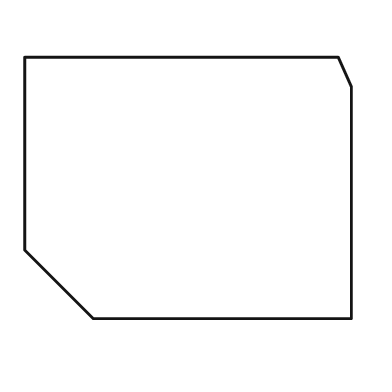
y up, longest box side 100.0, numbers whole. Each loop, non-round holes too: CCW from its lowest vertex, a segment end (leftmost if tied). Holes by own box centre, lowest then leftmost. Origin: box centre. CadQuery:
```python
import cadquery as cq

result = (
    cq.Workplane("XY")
    .moveTo(-29.0, -40.0)
    .lineTo(50.0, -40.0)
    .lineTo(50.0, 31.0)
    .lineTo(46.0, 40.0)
    .lineTo(-50.0, 40.0)
    .lineTo(-50.0, -19.0)
    .close()
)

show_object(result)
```